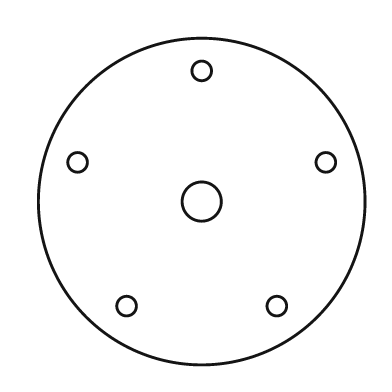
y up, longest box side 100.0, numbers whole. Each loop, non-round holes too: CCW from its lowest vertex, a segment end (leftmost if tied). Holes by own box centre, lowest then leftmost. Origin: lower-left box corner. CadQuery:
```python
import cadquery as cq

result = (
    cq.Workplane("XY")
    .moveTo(50.0, 50.0)
    .circle(50.0)
    .moveTo(27.0, 18.0)
    .circle(3.0)
    .moveTo(73.0, 18.0)
    .circle(3.0)
    .moveTo(50.0, 50.0)
    .circle(6.0)
    .moveTo(12.0, 62.0)
    .circle(3.0)
    .moveTo(88.0, 62.0)
    .circle(3.0)
    .moveTo(50.0, 90.0)
    .circle(3.0)
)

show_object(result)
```